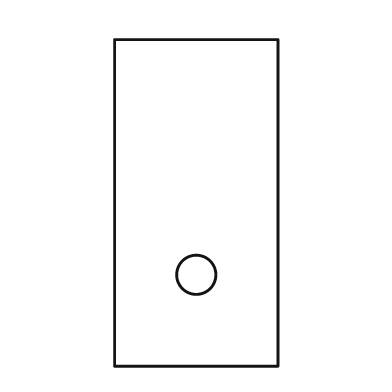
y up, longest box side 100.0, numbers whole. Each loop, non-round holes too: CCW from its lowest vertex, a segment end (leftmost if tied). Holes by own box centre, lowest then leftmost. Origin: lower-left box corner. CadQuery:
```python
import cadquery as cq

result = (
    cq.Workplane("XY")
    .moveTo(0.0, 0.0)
    .lineTo(50.0, 0.0)
    .lineTo(50.0, 100.0)
    .lineTo(0.0, 100.0)
    .close()
    .moveTo(25.0, 28.0)
    .circle(6.0)
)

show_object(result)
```